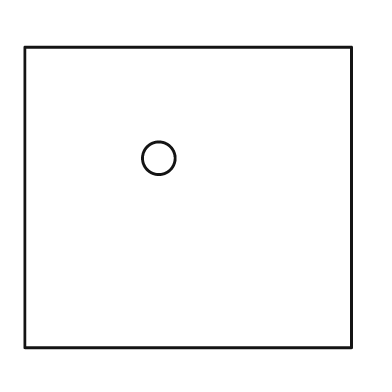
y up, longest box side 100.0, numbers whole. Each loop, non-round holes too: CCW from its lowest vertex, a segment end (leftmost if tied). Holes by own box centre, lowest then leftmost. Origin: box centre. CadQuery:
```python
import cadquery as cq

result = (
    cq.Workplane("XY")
    .moveTo(-50.0, -46.0)
    .lineTo(50.0, -46.0)
    .lineTo(50.0, 46.0)
    .lineTo(-50.0, 46.0)
    .close()
    .moveTo(-9.0, 12.0)
    .circle(5.0)
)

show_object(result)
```